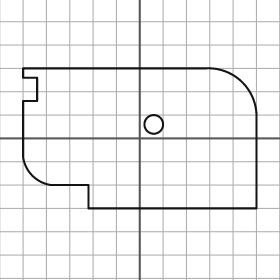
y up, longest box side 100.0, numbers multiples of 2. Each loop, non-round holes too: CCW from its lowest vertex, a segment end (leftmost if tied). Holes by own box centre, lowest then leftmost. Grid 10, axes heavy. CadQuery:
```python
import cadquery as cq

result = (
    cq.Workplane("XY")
    .moveTo(-22.0, -30.0)
    .lineTo(50.0, -30.0)
    .lineTo(50.0, 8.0)
    .threePointArc((44.0, 24.0), (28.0, 30.0))
    .lineTo(-50.0, 30.0)
    .lineTo(-50.0, 26.0)
    .lineTo(-44.0, 26.0)
    .lineTo(-44.0, 16.0)
    .lineTo(-50.0, 16.0)
    .lineTo(-50.0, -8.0)
    .threePointArc((-46.0, -16.0), (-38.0, -20.0))
    .lineTo(-22.0, -20.0)
    .close()
    .moveTo(6.0, 6.0)
    .circle(4.0)
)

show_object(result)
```